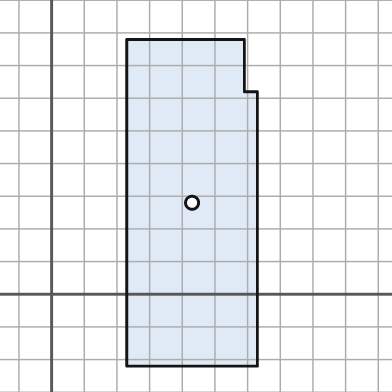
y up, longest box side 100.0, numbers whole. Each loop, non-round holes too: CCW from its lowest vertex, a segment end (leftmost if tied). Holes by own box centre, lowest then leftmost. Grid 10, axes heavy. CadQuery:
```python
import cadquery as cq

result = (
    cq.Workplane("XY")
    .moveTo(23.0, -22.0)
    .lineTo(63.0, -22.0)
    .lineTo(63.0, 62.0)
    .lineTo(59.0, 62.0)
    .lineTo(59.0, 78.0)
    .lineTo(23.0, 78.0)
    .close()
    .moveTo(43.0, 28.0)
    .circle(2.0)
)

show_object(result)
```